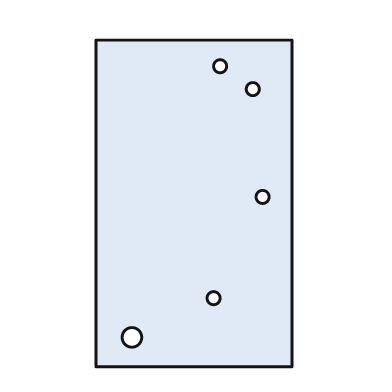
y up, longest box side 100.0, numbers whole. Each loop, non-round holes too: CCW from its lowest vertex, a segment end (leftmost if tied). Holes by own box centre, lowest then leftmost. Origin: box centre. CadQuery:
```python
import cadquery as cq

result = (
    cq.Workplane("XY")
    .moveTo(-30.0, -50.0)
    .lineTo(30.0, -50.0)
    .lineTo(30.0, 50.0)
    .lineTo(-30.0, 50.0)
    .close()
    .moveTo(-19.0, -41.0)
    .circle(3.0)
    .moveTo(6.0, -29.0)
    .circle(2.0)
    .moveTo(21.0, 2.0)
    .circle(2.0)
    .moveTo(18.0, 35.0)
    .circle(2.0)
    .moveTo(8.0, 42.0)
    .circle(2.0)
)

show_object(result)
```